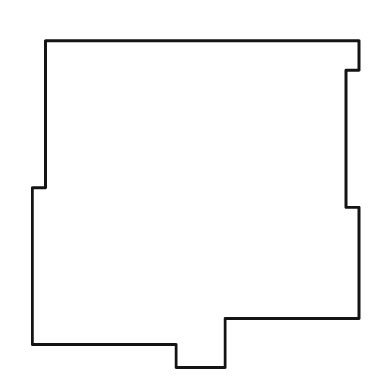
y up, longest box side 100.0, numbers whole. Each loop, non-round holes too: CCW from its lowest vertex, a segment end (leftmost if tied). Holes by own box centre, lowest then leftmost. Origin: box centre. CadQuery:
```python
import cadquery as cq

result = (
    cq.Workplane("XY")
    .moveTo(-6.0, -50.0)
    .lineTo(9.0, -50.0)
    .lineTo(9.0, -35.0)
    .lineTo(50.0, -35.0)
    .lineTo(50.0, -1.0)
    .lineTo(46.0, -1.0)
    .lineTo(46.0, 41.0)
    .lineTo(50.0, 41.0)
    .lineTo(50.0, 50.0)
    .lineTo(-46.0, 50.0)
    .lineTo(-46.0, 5.0)
    .lineTo(-50.0, 5.0)
    .lineTo(-50.0, -43.0)
    .lineTo(-6.0, -43.0)
    .close()
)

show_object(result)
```